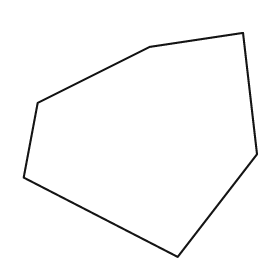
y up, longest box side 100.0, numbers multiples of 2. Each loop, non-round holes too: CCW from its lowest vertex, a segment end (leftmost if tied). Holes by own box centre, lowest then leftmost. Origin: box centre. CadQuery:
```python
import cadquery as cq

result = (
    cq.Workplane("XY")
    .moveTo(16.0, -48.0)
    .lineTo(50.0, -4.0)
    .lineTo(44.0, 48.0)
    .lineTo(4.0, 42.0)
    .lineTo(-44.0, 18.0)
    .lineTo(-50.0, -14.0)
    .close()
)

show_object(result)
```